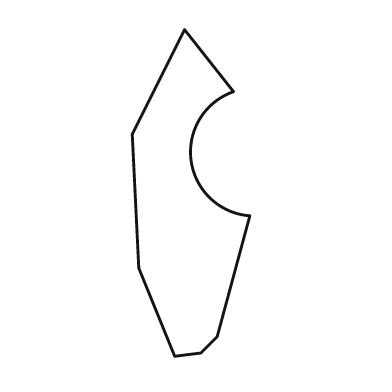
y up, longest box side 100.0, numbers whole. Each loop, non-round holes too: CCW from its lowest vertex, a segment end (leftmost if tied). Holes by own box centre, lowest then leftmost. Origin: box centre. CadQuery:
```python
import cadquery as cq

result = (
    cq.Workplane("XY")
    .moveTo(-5.0, -50.0)
    .lineTo(3.0, -49.0)
    .lineTo(8.0, -44.0)
    .lineTo(18.0, -7.0)
    .threePointArc((0.0, 10.0), (13.0, 31.0))
    .lineTo(-2.0, 50.0)
    .lineTo(-18.0, 18.0)
    .lineTo(-16.0, -23.0)
    .close()
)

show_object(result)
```